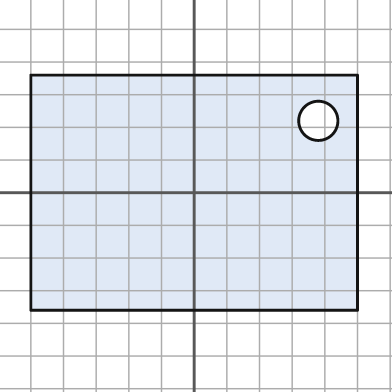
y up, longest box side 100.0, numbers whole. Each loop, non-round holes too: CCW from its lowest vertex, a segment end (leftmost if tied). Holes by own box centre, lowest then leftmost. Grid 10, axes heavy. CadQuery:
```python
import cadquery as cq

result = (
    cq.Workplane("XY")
    .moveTo(-50.0, -36.0)
    .lineTo(50.0, -36.0)
    .lineTo(50.0, 36.0)
    .lineTo(-50.0, 36.0)
    .close()
    .moveTo(38.0, 22.0)
    .circle(6.0)
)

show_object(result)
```